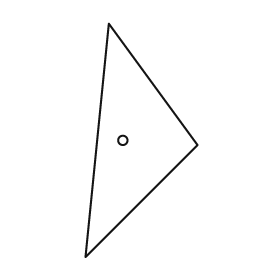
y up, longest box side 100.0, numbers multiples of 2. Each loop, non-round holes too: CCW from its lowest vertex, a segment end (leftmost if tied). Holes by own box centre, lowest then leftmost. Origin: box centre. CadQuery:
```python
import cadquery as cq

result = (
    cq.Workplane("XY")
    .moveTo(-24.0, -50.0)
    .lineTo(24.0, -2.0)
    .lineTo(-14.0, 50.0)
    .close()
    .moveTo(-8.0, 0.0)
    .circle(2.0)
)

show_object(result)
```